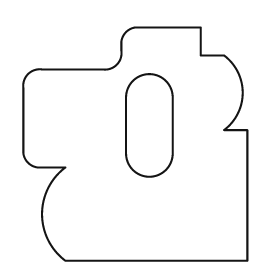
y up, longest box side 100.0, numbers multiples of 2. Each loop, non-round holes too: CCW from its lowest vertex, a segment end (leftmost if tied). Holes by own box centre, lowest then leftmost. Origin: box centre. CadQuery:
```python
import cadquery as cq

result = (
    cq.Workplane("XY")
    .moveTo(-30.0, -50.0)
    .lineTo(48.0, -50.0)
    .lineTo(48.0, 6.0)
    .lineTo(38.0, 6.0)
    .threePointArc((46.0, 22.0), (38.0, 38.0))
    .lineTo(28.0, 38.0)
    .lineTo(28.0, 50.0)
    .lineTo(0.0, 50.0)
    .threePointArc((-4.0, 48.0), (-6.0, 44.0))
    .lineTo(-6.0, 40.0)
    .threePointArc((-8.0, 34.0), (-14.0, 32.0))
    .lineTo(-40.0, 32.0)
    .threePointArc((-46.0, 30.0), (-48.0, 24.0))
    .lineTo(-48.0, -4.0)
    .threePointArc((-46.0, -8.0), (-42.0, -10.0))
    .lineTo(-30.0, -10.0)
    .threePointArc((-40.0, -30.0), (-30.0, -50.0))
    .close()
    .moveTo(-4.0, -4.0)
    .threePointArc((6.0, -14.0), (16.0, -4.0))
    .lineTo(16.0, 20.0)
    .threePointArc((6.0, 30.0), (-4.0, 20.0))
    .close()
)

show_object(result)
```